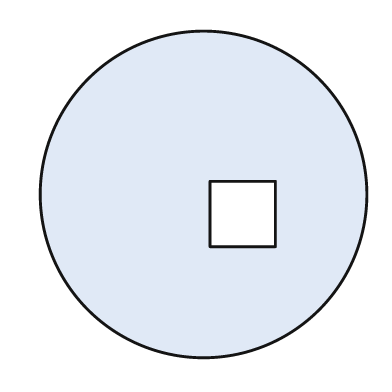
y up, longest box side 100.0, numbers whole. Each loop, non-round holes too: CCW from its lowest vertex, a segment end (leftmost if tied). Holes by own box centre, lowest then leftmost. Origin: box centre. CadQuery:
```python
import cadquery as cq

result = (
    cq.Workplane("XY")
    .moveTo(0.0, 0.0)
    .circle(50.0)
    .moveTo(2.0, -16.0)
    .lineTo(22.0, -16.0)
    .lineTo(22.0, 4.0)
    .lineTo(2.0, 4.0)
    .close()
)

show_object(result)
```